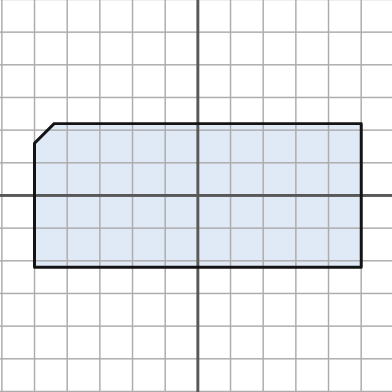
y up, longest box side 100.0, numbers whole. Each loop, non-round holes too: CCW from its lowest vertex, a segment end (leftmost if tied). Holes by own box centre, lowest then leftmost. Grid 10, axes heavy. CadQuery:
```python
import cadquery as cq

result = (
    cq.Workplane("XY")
    .moveTo(-50.0, -22.0)
    .lineTo(50.0, -22.0)
    .lineTo(50.0, 22.0)
    .lineTo(-44.0, 22.0)
    .lineTo(-50.0, 16.0)
    .close()
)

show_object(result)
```